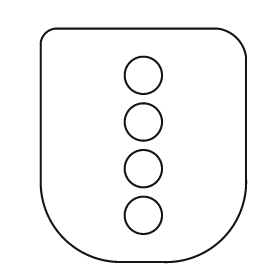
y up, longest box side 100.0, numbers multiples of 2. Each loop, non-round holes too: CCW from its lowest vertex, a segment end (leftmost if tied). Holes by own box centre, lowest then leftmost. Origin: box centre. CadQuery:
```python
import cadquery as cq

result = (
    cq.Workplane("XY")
    .moveTo(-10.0, -50.0)
    .lineTo(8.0, -50.0)
    .threePointArc((34.0, -40.0), (44.0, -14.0))
    .lineTo(44.0, 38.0)
    .threePointArc((40.0, 46.0), (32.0, 50.0))
    .lineTo(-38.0, 50.0)
    .threePointArc((-42.0, 48.0), (-44.0, 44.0))
    .lineTo(-44.0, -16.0)
    .threePointArc((-34.0, -40.0), (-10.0, -50.0))
    .close()
    .moveTo(0.0, -30.0)
    .circle(8.0)
    .moveTo(0.0, -10.0)
    .circle(8.0)
    .moveTo(0.0, 10.0)
    .circle(8.0)
    .moveTo(0.0, 30.0)
    .circle(8.0)
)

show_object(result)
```